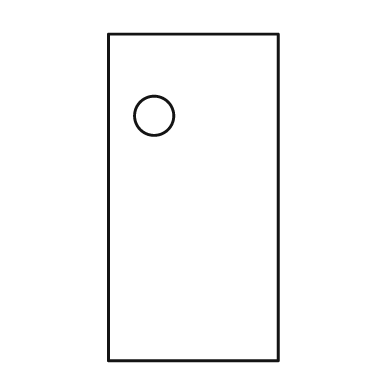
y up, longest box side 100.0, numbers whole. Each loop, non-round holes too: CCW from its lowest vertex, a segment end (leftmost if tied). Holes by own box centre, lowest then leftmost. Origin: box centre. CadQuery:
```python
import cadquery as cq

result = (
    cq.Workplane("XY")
    .moveTo(-26.0, -50.0)
    .lineTo(26.0, -50.0)
    .lineTo(26.0, 50.0)
    .lineTo(-26.0, 50.0)
    .close()
    .moveTo(-12.0, 25.0)
    .circle(6.0)
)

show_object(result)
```